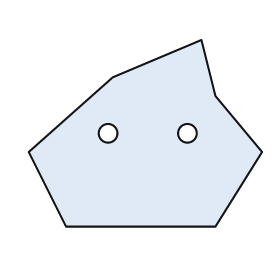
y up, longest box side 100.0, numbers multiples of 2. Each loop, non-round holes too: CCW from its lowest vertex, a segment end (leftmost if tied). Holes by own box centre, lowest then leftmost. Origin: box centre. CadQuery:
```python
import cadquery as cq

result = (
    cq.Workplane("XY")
    .moveTo(-34.0, -40.0)
    .lineTo(30.0, -40.0)
    .lineTo(50.0, -8.0)
    .lineTo(30.0, 16.0)
    .lineTo(24.0, 40.0)
    .lineTo(-14.0, 24.0)
    .lineTo(-50.0, -8.0)
    .close()
    .moveTo(-16.0, 0.0)
    .circle(4.0)
    .moveTo(18.0, 0.0)
    .circle(4.0)
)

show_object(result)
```